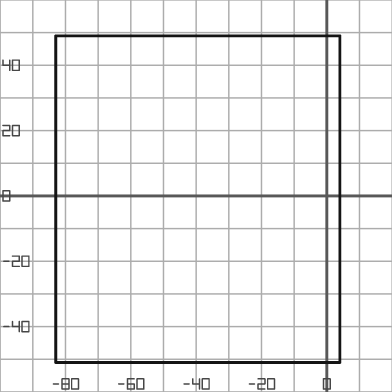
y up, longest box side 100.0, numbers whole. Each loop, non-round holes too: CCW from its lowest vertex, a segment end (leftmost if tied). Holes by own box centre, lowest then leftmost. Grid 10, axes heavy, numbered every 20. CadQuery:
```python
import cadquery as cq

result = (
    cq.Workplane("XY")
    .moveTo(-83.0, -51.0)
    .lineTo(4.0, -51.0)
    .lineTo(4.0, 49.0)
    .lineTo(-83.0, 49.0)
    .close()
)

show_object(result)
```